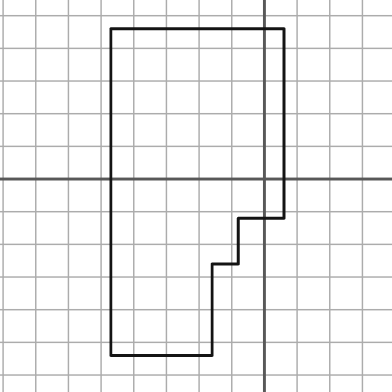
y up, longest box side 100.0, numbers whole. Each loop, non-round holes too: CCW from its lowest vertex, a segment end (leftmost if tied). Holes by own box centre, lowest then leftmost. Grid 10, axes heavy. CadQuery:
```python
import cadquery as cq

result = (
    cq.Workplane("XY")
    .moveTo(-47.0, -54.0)
    .lineTo(-16.0, -54.0)
    .lineTo(-16.0, -26.0)
    .lineTo(-8.0, -26.0)
    .lineTo(-8.0, -12.0)
    .lineTo(6.0, -12.0)
    .lineTo(6.0, 46.0)
    .lineTo(-47.0, 46.0)
    .close()
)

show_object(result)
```